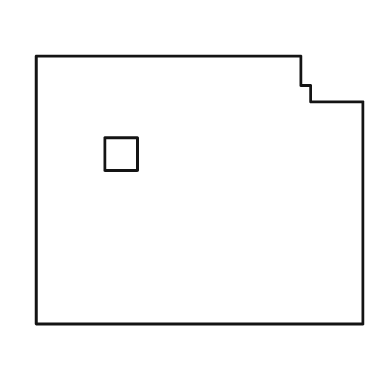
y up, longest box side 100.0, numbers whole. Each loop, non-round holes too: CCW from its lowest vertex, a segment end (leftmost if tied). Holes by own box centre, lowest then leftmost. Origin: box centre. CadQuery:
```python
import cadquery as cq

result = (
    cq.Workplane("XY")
    .moveTo(-50.0, -41.0)
    .lineTo(50.0, -41.0)
    .lineTo(50.0, 27.0)
    .lineTo(34.0, 27.0)
    .lineTo(34.0, 32.0)
    .lineTo(31.0, 32.0)
    .lineTo(31.0, 41.0)
    .lineTo(-50.0, 41.0)
    .close()
    .moveTo(-29.0, 6.0)
    .lineTo(-19.0, 6.0)
    .lineTo(-19.0, 16.0)
    .lineTo(-29.0, 16.0)
    .close()
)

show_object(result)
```